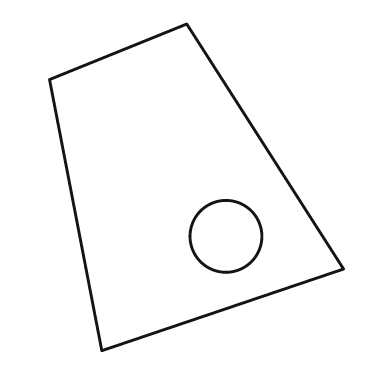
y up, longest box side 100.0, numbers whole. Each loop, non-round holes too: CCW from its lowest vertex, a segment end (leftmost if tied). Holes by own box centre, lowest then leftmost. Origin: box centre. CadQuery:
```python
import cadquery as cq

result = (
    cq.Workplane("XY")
    .moveTo(-29.0, -50.0)
    .lineTo(45.0, -25.0)
    .lineTo(-3.0, 50.0)
    .lineTo(-45.0, 33.0)
    .close()
    .moveTo(9.0, -15.0)
    .circle(11.0)
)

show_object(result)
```